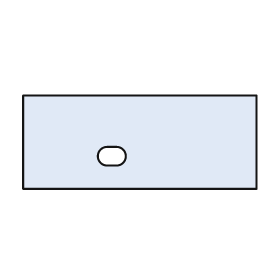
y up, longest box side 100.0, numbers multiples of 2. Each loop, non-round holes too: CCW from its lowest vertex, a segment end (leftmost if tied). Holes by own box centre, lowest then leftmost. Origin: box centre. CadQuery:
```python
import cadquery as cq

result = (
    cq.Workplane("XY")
    .moveTo(-50.0, -20.0)
    .lineTo(50.0, -20.0)
    .lineTo(50.0, 20.0)
    .lineTo(-50.0, 20.0)
    .close()
    .moveTo(-14.0, -10.0)
    .lineTo(-10.0, -10.0)
    .threePointArc((-6.0, -6.0), (-10.0, -2.0))
    .lineTo(-14.0, -2.0)
    .threePointArc((-18.0, -6.0), (-14.0, -10.0))
    .close()
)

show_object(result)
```